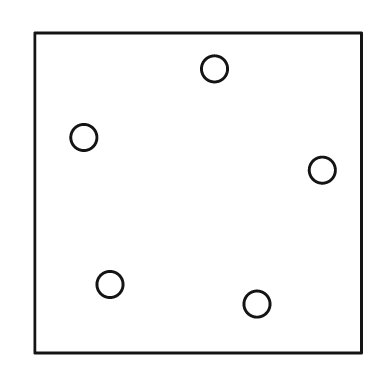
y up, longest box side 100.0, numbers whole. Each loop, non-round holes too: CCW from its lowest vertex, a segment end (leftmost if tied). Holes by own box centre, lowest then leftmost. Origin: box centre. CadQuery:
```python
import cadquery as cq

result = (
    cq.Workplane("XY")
    .moveTo(-50.0, -49.0)
    .lineTo(50.0, -49.0)
    .lineTo(50.0, 49.0)
    .lineTo(-50.0, 49.0)
    .close()
    .moveTo(18.0, -34.0)
    .circle(4.0)
    .moveTo(-27.0, -28.0)
    .circle(4.0)
    .moveTo(38.0, 7.0)
    .circle(4.0)
    .moveTo(-35.0, 17.0)
    .circle(4.0)
    .moveTo(5.0, 38.0)
    .circle(4.0)
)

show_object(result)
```